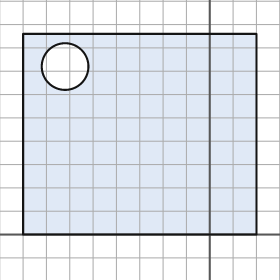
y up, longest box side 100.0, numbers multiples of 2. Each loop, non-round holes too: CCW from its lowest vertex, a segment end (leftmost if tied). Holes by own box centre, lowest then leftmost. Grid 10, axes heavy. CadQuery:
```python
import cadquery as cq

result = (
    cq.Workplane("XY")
    .moveTo(-80.0, 0.0)
    .lineTo(20.0, 0.0)
    .lineTo(20.0, 86.0)
    .lineTo(-80.0, 86.0)
    .close()
    .moveTo(-62.0, 72.0)
    .circle(10.0)
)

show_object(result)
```